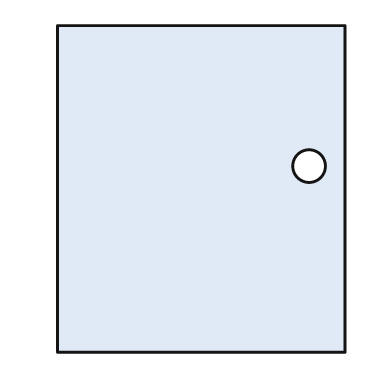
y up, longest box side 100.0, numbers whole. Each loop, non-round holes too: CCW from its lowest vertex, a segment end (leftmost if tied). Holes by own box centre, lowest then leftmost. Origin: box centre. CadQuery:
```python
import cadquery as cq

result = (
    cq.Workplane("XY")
    .moveTo(-44.0, -50.0)
    .lineTo(44.0, -50.0)
    .lineTo(44.0, 50.0)
    .lineTo(-44.0, 50.0)
    .close()
    .moveTo(33.0, 7.0)
    .circle(5.0)
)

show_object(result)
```